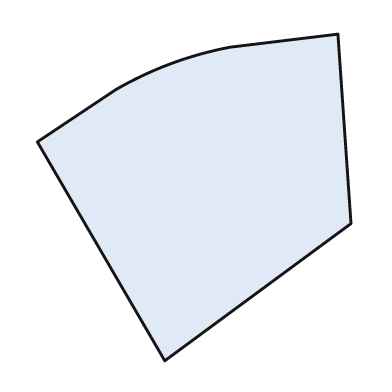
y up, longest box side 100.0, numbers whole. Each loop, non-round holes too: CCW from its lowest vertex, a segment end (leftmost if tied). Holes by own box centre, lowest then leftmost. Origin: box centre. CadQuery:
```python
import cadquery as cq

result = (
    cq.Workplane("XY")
    .moveTo(-9.0, -50.0)
    .lineTo(48.0, -8.0)
    .lineTo(44.0, 50.0)
    .lineTo(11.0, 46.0)
    .threePointArc((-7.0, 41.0), (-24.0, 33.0))
    .lineTo(-48.0, 17.0)
    .close()
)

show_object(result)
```